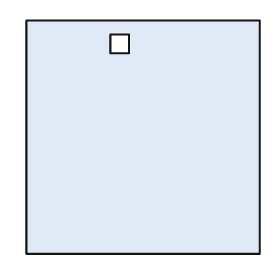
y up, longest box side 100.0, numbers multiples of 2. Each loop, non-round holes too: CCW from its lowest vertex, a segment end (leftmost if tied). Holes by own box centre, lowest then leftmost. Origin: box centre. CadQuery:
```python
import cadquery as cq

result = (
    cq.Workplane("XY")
    .moveTo(-50.0, -50.0)
    .lineTo(50.0, -50.0)
    .lineTo(50.0, 50.0)
    .lineTo(-50.0, 50.0)
    .close()
    .moveTo(-14.0, 36.0)
    .lineTo(-6.0, 36.0)
    .lineTo(-6.0, 44.0)
    .lineTo(-14.0, 44.0)
    .close()
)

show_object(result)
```